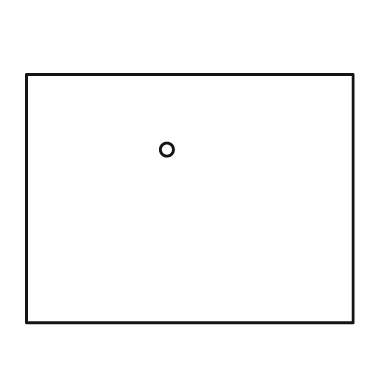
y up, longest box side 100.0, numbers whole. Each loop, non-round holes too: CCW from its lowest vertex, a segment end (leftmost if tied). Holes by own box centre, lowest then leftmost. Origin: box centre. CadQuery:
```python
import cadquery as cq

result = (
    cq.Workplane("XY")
    .moveTo(-50.0, -38.0)
    .lineTo(50.0, -38.0)
    .lineTo(50.0, 38.0)
    .lineTo(-50.0, 38.0)
    .close()
    .moveTo(-7.0, 15.0)
    .circle(2.0)
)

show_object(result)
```